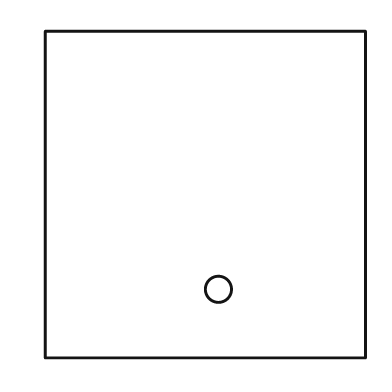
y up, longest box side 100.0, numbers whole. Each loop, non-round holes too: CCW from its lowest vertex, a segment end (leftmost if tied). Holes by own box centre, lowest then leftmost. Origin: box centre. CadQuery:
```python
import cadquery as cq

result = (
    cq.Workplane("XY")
    .moveTo(-49.0, -50.0)
    .lineTo(49.0, -50.0)
    .lineTo(49.0, 50.0)
    .lineTo(-49.0, 50.0)
    .close()
    .moveTo(4.0, -29.0)
    .circle(4.0)
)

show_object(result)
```